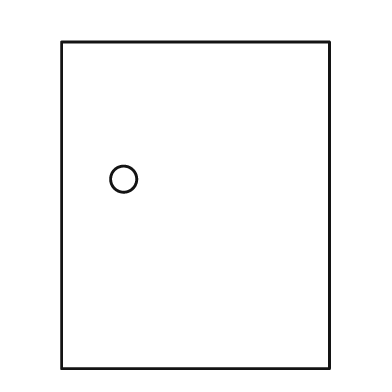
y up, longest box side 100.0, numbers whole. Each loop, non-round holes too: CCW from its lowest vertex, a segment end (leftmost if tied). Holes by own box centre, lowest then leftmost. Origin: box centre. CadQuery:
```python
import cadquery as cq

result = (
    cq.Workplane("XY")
    .moveTo(-41.0, -50.0)
    .lineTo(41.0, -50.0)
    .lineTo(41.0, 50.0)
    .lineTo(-41.0, 50.0)
    .close()
    .moveTo(-22.0, 8.0)
    .circle(4.0)
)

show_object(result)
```